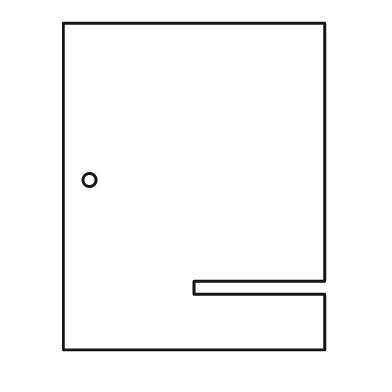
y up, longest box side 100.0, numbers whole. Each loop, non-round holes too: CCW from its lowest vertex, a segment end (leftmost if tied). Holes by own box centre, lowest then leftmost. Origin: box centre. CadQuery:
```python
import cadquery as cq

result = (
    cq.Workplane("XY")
    .moveTo(-40.0, -50.0)
    .lineTo(40.0, -50.0)
    .lineTo(40.0, -33.0)
    .lineTo(0.0, -33.0)
    .lineTo(0.0, -29.0)
    .lineTo(40.0, -29.0)
    .lineTo(40.0, 50.0)
    .lineTo(-40.0, 50.0)
    .close()
    .moveTo(-32.0, 2.0)
    .circle(2.0)
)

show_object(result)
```